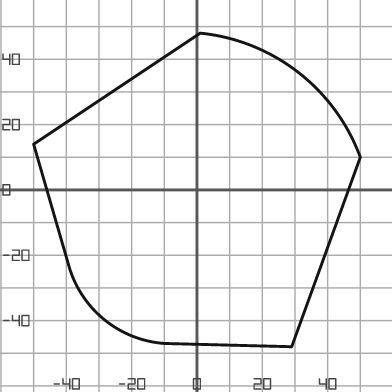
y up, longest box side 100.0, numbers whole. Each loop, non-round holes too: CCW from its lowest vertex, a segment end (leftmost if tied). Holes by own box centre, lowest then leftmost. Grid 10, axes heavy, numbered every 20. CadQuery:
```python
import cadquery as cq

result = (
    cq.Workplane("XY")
    .moveTo(29.0, -48.0)
    .lineTo(50.0, 10.0)
    .threePointArc((31.0, 36.0), (1.0, 48.0))
    .lineTo(-50.0, 14.0)
    .lineTo(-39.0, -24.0)
    .threePointArc((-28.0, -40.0), (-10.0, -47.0))
    .close()
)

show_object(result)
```